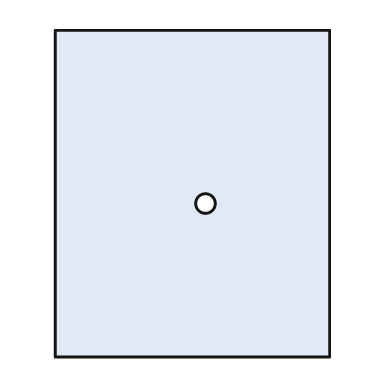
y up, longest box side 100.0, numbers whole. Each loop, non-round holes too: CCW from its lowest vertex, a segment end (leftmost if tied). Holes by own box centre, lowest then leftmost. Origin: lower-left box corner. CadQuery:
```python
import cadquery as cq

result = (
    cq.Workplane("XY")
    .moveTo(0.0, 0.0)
    .lineTo(84.0, 0.0)
    .lineTo(84.0, 100.0)
    .lineTo(0.0, 100.0)
    .close()
    .moveTo(46.0, 47.0)
    .circle(3.0)
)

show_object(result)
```